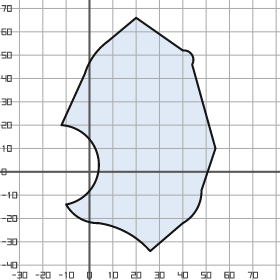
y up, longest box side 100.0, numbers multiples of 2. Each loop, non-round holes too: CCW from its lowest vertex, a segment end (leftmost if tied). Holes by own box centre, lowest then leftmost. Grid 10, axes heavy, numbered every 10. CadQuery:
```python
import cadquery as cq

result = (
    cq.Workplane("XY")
    .moveTo(26.0, -34.0)
    .lineTo(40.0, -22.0)
    .threePointArc((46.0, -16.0), (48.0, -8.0))
    .lineTo(54.0, 10.0)
    .lineTo(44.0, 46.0)
    .threePointArc((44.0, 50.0), (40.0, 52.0))
    .lineTo(20.0, 66.0)
    .lineTo(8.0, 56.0)
    .threePointArc((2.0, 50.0), (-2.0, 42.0))
    .lineTo(-12.0, 20.0)
    .threePointArc((4.0, 4.0), (-10.0, -14.0))
    .threePointArc((-4.0, -20.0), (4.0, -22.0))
    .threePointArc((16.0, -26.0), (26.0, -34.0))
    .close()
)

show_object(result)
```